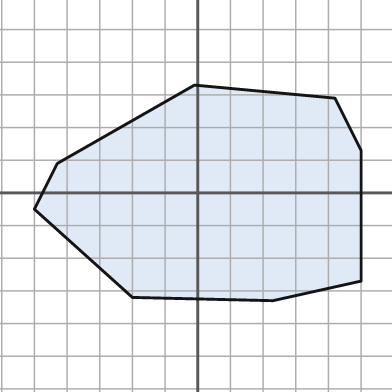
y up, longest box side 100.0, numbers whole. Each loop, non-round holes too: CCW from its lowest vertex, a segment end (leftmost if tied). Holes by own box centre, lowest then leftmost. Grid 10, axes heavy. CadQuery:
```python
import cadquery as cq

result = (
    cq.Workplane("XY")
    .moveTo(23.0, -33.0)
    .lineTo(50.0, -27.0)
    .lineTo(50.0, 13.0)
    .lineTo(42.0, 29.0)
    .lineTo(-1.0, 33.0)
    .lineTo(-43.0, 9.0)
    .lineTo(-50.0, -5.0)
    .lineTo(-20.0, -32.0)
    .close()
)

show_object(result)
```